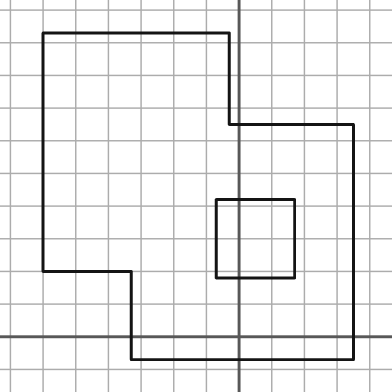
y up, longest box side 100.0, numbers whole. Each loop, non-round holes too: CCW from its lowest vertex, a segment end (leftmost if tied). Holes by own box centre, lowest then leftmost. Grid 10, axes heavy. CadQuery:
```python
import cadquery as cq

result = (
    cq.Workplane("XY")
    .moveTo(-33.0, -7.0)
    .lineTo(35.0, -7.0)
    .lineTo(35.0, 65.0)
    .lineTo(-3.0, 65.0)
    .lineTo(-3.0, 93.0)
    .lineTo(-60.0, 93.0)
    .lineTo(-60.0, 20.0)
    .lineTo(-33.0, 20.0)
    .close()
    .moveTo(-7.0, 18.0)
    .lineTo(17.0, 18.0)
    .lineTo(17.0, 42.0)
    .lineTo(-7.0, 42.0)
    .close()
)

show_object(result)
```